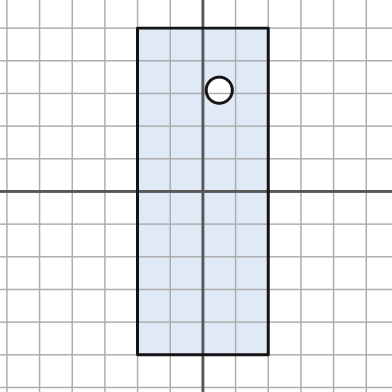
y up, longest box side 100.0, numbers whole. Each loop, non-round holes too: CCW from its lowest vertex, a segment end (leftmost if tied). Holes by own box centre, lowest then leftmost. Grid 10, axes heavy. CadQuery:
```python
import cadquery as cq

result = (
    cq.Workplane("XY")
    .moveTo(-20.0, -50.0)
    .lineTo(20.0, -50.0)
    .lineTo(20.0, 50.0)
    .lineTo(-20.0, 50.0)
    .close()
    .moveTo(5.0, 31.0)
    .circle(4.0)
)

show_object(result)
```